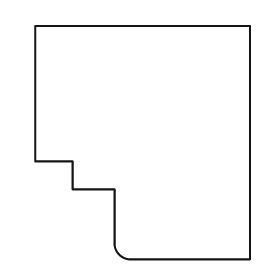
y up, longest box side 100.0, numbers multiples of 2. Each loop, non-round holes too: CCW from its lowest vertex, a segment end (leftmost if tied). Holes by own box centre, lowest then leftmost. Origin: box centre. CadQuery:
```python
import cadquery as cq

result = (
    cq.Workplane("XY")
    .moveTo(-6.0, -50.0)
    .lineTo(46.0, -50.0)
    .lineTo(46.0, 50.0)
    .lineTo(-46.0, 50.0)
    .lineTo(-46.0, -8.0)
    .lineTo(-30.0, -8.0)
    .lineTo(-30.0, -20.0)
    .lineTo(-12.0, -20.0)
    .lineTo(-12.0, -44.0)
    .threePointArc((-10.0, -48.0), (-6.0, -50.0))
    .close()
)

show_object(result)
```